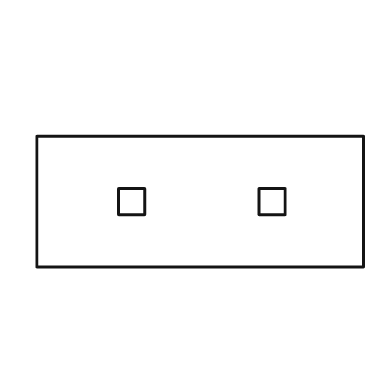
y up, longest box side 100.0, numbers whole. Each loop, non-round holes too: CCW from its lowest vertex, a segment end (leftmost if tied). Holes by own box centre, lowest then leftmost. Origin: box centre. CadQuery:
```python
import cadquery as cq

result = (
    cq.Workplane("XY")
    .moveTo(-50.0, -20.0)
    .lineTo(50.0, -20.0)
    .lineTo(50.0, 20.0)
    .lineTo(-50.0, 20.0)
    .close()
    .moveTo(-25.0, -4.0)
    .lineTo(-17.0, -4.0)
    .lineTo(-17.0, 4.0)
    .lineTo(-25.0, 4.0)
    .close()
    .moveTo(18.0, -4.0)
    .lineTo(26.0, -4.0)
    .lineTo(26.0, 4.0)
    .lineTo(18.0, 4.0)
    .close()
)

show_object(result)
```